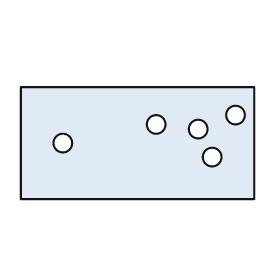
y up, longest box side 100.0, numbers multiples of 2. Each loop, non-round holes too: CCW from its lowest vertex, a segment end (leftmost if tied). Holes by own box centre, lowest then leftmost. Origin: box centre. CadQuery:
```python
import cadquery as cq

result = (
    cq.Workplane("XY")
    .moveTo(-50.0, -24.0)
    .lineTo(50.0, -24.0)
    .lineTo(50.0, 24.0)
    .lineTo(-50.0, 24.0)
    .close()
    .moveTo(32.0, -6.0)
    .circle(4.0)
    .moveTo(-32.0, 0.0)
    .circle(4.0)
    .moveTo(26.0, 6.0)
    .circle(4.0)
    .moveTo(8.0, 8.0)
    .circle(4.0)
    .moveTo(42.0, 12.0)
    .circle(4.0)
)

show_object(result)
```